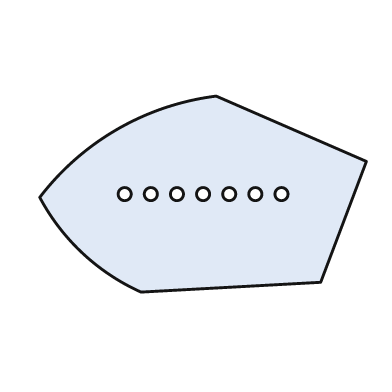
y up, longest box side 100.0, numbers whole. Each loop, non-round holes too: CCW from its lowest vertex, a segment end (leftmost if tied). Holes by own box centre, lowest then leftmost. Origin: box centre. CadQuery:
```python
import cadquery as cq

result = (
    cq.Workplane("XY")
    .moveTo(-19.0, -30.0)
    .lineTo(36.0, -27.0)
    .lineTo(50.0, 10.0)
    .lineTo(4.0, 30.0)
    .threePointArc((-26.0, 20.0), (-50.0, -1.0))
    .threePointArc((-37.0, -18.0), (-19.0, -30.0))
    .close()
    .moveTo(-24.0, 0.0)
    .circle(2.0)
    .moveTo(-16.0, 0.0)
    .circle(2.0)
    .moveTo(-8.0, 0.0)
    .circle(2.0)
    .moveTo(0.0, 0.0)
    .circle(2.0)
    .moveTo(8.0, 0.0)
    .circle(2.0)
    .moveTo(16.0, 0.0)
    .circle(2.0)
    .moveTo(24.0, 0.0)
    .circle(2.0)
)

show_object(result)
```